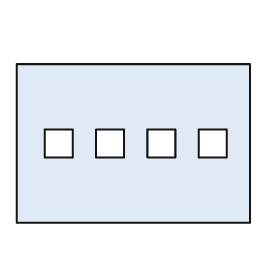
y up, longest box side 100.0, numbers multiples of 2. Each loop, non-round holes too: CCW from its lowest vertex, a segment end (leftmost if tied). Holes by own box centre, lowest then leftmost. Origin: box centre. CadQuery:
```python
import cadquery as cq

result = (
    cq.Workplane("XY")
    .moveTo(-50.0, -34.0)
    .lineTo(50.0, -34.0)
    .lineTo(50.0, 34.0)
    .lineTo(-50.0, 34.0)
    .close()
    .moveTo(-38.0, -6.0)
    .lineTo(-26.0, -6.0)
    .lineTo(-26.0, 6.0)
    .lineTo(-38.0, 6.0)
    .close()
    .moveTo(-16.0, -6.0)
    .lineTo(-4.0, -6.0)
    .lineTo(-4.0, 6.0)
    .lineTo(-16.0, 6.0)
    .close()
    .moveTo(6.0, -6.0)
    .lineTo(18.0, -6.0)
    .lineTo(18.0, 6.0)
    .lineTo(6.0, 6.0)
    .close()
    .moveTo(28.0, -6.0)
    .lineTo(40.0, -6.0)
    .lineTo(40.0, 6.0)
    .lineTo(28.0, 6.0)
    .close()
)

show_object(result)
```